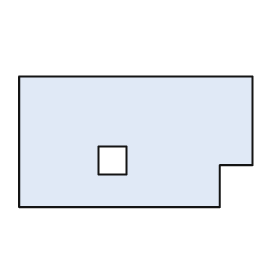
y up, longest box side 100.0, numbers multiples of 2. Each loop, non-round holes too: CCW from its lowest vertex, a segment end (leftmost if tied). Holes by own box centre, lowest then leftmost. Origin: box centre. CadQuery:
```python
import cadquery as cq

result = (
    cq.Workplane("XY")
    .moveTo(-50.0, -28.0)
    .lineTo(36.0, -28.0)
    .lineTo(36.0, -10.0)
    .lineTo(50.0, -10.0)
    .lineTo(50.0, 28.0)
    .lineTo(-50.0, 28.0)
    .close()
    .moveTo(-16.0, -14.0)
    .lineTo(-4.0, -14.0)
    .lineTo(-4.0, -2.0)
    .lineTo(-16.0, -2.0)
    .close()
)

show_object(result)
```